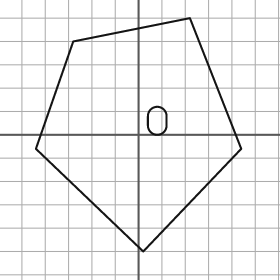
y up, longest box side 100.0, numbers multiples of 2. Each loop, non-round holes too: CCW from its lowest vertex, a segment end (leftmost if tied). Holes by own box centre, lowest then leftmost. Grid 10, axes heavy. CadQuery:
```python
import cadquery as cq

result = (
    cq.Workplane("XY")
    .moveTo(2.0, -50.0)
    .lineTo(44.0, -6.0)
    .lineTo(22.0, 50.0)
    .lineTo(-28.0, 40.0)
    .lineTo(-44.0, -6.0)
    .close()
    .moveTo(4.0, 4.0)
    .threePointArc((8.0, 0.0), (12.0, 4.0))
    .lineTo(12.0, 8.0)
    .threePointArc((8.0, 12.0), (4.0, 8.0))
    .close()
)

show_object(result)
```